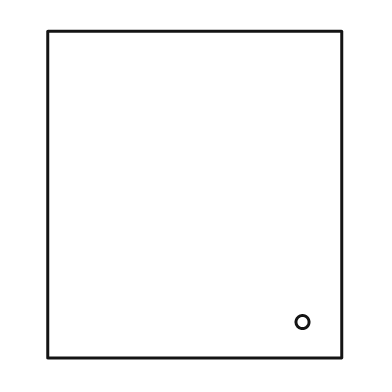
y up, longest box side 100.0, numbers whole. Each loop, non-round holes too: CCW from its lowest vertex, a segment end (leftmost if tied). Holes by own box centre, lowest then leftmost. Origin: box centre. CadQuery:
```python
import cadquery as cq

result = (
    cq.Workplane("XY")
    .moveTo(-45.0, -50.0)
    .lineTo(45.0, -50.0)
    .lineTo(45.0, 50.0)
    .lineTo(-45.0, 50.0)
    .close()
    .moveTo(33.0, -39.0)
    .circle(2.0)
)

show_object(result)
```